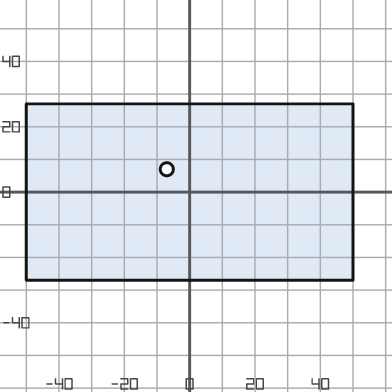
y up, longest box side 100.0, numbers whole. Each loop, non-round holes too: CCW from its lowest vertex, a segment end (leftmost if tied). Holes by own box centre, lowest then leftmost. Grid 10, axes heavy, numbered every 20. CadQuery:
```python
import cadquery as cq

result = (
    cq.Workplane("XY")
    .moveTo(-50.0, -27.0)
    .lineTo(50.0, -27.0)
    .lineTo(50.0, 27.0)
    .lineTo(-50.0, 27.0)
    .close()
    .moveTo(-7.0, 7.0)
    .circle(2.0)
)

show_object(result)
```